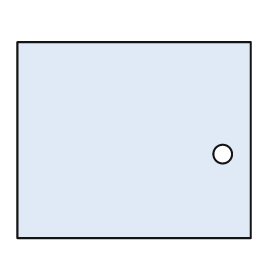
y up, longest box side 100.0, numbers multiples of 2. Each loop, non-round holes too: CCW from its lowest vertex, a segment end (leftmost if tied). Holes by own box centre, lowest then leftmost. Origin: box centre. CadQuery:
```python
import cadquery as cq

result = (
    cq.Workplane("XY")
    .moveTo(-50.0, -42.0)
    .lineTo(50.0, -42.0)
    .lineTo(50.0, 42.0)
    .lineTo(-50.0, 42.0)
    .close()
    .moveTo(38.0, -6.0)
    .circle(4.0)
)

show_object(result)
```